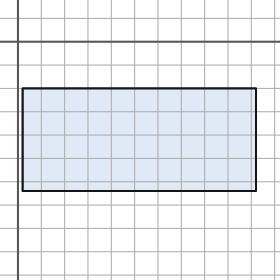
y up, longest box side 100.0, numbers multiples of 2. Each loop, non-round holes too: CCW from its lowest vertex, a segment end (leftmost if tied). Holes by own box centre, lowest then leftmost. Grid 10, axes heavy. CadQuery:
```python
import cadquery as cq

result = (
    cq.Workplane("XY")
    .moveTo(2.0, -64.0)
    .lineTo(102.0, -64.0)
    .lineTo(102.0, -20.0)
    .lineTo(2.0, -20.0)
    .close()
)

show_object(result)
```